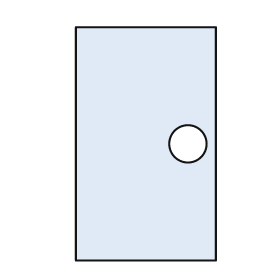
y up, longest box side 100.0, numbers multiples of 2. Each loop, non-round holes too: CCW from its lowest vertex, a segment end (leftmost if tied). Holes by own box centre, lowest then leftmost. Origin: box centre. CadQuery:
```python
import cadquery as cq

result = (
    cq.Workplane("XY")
    .moveTo(-30.0, -50.0)
    .lineTo(30.0, -50.0)
    .lineTo(30.0, 50.0)
    .lineTo(-30.0, 50.0)
    .close()
    .moveTo(18.0, 0.0)
    .circle(8.0)
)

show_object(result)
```